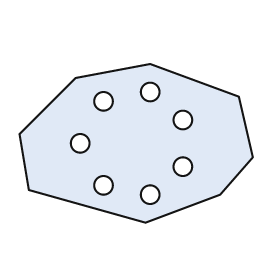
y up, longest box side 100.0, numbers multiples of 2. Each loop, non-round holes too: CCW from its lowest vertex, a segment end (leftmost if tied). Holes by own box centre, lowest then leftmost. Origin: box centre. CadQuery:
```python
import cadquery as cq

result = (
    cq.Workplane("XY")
    .moveTo(4.0, -34.0)
    .lineTo(36.0, -22.0)
    .lineTo(50.0, -6.0)
    .lineTo(44.0, 20.0)
    .lineTo(6.0, 34.0)
    .lineTo(-26.0, 28.0)
    .lineTo(-50.0, 4.0)
    .lineTo(-46.0, -20.0)
    .close()
    .moveTo(6.0, -22.0)
    .circle(4.0)
    .moveTo(-14.0, -18.0)
    .circle(4.0)
    .moveTo(20.0, -10.0)
    .circle(4.0)
    .moveTo(-24.0, 0.0)
    .circle(4.0)
    .moveTo(20.0, 10.0)
    .circle(4.0)
    .moveTo(-14.0, 18.0)
    .circle(4.0)
    .moveTo(6.0, 22.0)
    .circle(4.0)
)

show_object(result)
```